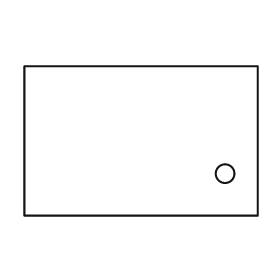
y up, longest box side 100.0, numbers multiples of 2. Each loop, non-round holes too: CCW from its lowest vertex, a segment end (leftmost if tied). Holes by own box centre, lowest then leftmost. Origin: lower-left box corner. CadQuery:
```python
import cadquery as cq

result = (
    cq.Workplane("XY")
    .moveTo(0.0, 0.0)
    .lineTo(100.0, 0.0)
    .lineTo(100.0, 64.0)
    .lineTo(0.0, 64.0)
    .close()
    .moveTo(86.0, 18.0)
    .circle(4.0)
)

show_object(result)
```